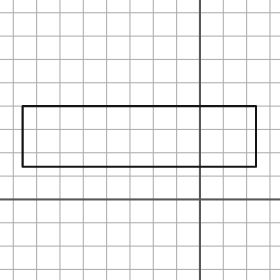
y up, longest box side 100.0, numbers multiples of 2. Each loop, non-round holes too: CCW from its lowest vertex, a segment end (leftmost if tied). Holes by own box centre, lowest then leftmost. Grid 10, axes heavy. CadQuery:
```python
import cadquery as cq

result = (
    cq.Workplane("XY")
    .moveTo(-76.0, 14.0)
    .lineTo(24.0, 14.0)
    .lineTo(24.0, 40.0)
    .lineTo(-76.0, 40.0)
    .close()
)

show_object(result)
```